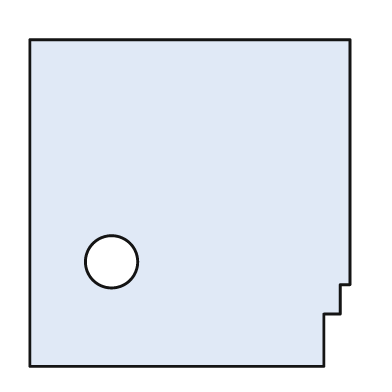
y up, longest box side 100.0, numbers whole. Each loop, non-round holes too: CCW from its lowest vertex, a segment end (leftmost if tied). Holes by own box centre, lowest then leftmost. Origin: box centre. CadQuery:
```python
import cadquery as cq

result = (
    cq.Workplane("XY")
    .moveTo(-49.0, -50.0)
    .lineTo(41.0, -50.0)
    .lineTo(41.0, -34.0)
    .lineTo(46.0, -34.0)
    .lineTo(46.0, -25.0)
    .lineTo(49.0, -25.0)
    .lineTo(49.0, 50.0)
    .lineTo(-49.0, 50.0)
    .close()
    .moveTo(-24.0, -18.0)
    .circle(8.0)
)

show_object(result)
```